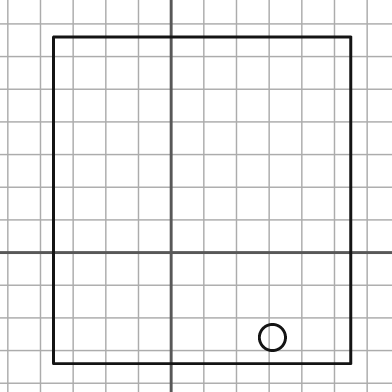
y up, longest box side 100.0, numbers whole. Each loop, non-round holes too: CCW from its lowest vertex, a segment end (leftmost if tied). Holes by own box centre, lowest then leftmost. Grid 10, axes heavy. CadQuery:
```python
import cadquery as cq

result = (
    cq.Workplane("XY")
    .moveTo(-36.0, -34.0)
    .lineTo(55.0, -34.0)
    .lineTo(55.0, 66.0)
    .lineTo(-36.0, 66.0)
    .close()
    .moveTo(31.0, -26.0)
    .circle(4.0)
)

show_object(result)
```